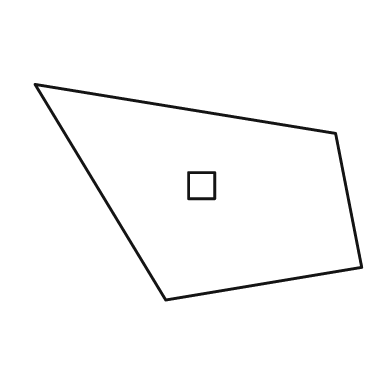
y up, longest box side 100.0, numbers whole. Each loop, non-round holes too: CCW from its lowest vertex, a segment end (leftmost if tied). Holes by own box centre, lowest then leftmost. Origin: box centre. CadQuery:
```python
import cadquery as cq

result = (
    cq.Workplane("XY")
    .moveTo(-10.0, -33.0)
    .lineTo(50.0, -23.0)
    .lineTo(42.0, 18.0)
    .lineTo(-50.0, 33.0)
    .close()
    .moveTo(-3.0, -2.0)
    .lineTo(5.0, -2.0)
    .lineTo(5.0, 6.0)
    .lineTo(-3.0, 6.0)
    .close()
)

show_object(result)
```